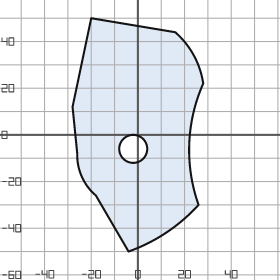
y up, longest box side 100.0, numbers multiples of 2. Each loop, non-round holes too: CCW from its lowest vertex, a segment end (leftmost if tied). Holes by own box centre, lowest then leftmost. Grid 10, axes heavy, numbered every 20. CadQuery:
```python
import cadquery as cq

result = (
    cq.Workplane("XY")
    .moveTo(-4.0, -50.0)
    .threePointArc((12.0, -42.0), (26.0, -30.0))
    .threePointArc((22.0, -4.0), (28.0, 22.0))
    .threePointArc((24.0, 34.0), (16.0, 44.0))
    .lineTo(-20.0, 50.0)
    .lineTo(-28.0, 12.0)
    .lineTo(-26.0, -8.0)
    .threePointArc((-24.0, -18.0), (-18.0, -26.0))
    .close()
    .moveTo(-2.0, -6.0)
    .circle(6.0)
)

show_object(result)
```